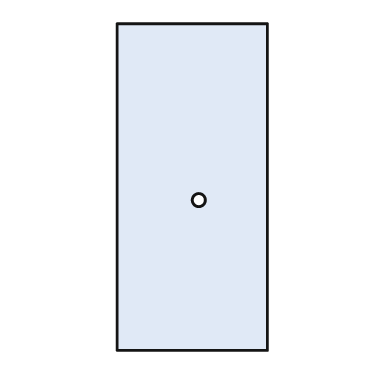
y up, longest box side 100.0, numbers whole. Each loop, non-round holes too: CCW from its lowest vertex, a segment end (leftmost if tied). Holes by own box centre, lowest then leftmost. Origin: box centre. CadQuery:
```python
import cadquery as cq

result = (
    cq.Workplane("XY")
    .moveTo(-23.0, -50.0)
    .lineTo(23.0, -50.0)
    .lineTo(23.0, 50.0)
    .lineTo(-23.0, 50.0)
    .close()
    .moveTo(2.0, -4.0)
    .circle(2.0)
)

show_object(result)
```